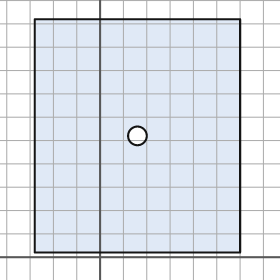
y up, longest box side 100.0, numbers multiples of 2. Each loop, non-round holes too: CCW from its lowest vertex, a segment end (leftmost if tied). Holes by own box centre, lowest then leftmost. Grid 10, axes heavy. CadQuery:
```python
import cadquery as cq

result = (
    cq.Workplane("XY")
    .moveTo(-28.0, 2.0)
    .lineTo(60.0, 2.0)
    .lineTo(60.0, 102.0)
    .lineTo(-28.0, 102.0)
    .close()
    .moveTo(16.0, 52.0)
    .circle(4.0)
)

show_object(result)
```